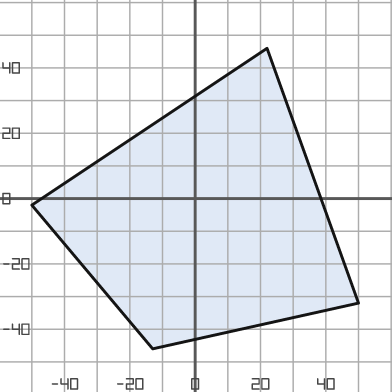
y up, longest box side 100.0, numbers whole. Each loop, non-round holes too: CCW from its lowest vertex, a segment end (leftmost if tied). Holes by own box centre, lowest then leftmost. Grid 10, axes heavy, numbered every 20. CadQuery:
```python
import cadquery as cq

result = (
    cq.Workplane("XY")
    .moveTo(-13.0, -46.0)
    .lineTo(50.0, -32.0)
    .lineTo(22.0, 46.0)
    .lineTo(-50.0, -2.0)
    .close()
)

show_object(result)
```